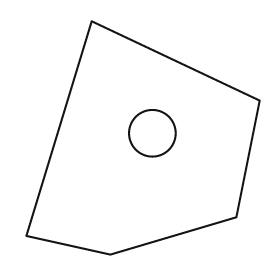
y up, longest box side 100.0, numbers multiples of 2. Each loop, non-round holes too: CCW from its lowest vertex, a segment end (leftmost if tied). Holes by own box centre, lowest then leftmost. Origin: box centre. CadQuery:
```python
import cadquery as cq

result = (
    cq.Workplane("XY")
    .moveTo(-14.0, -50.0)
    .lineTo(40.0, -34.0)
    .lineTo(50.0, 16.0)
    .lineTo(-22.0, 50.0)
    .lineTo(-50.0, -42.0)
    .close()
    .moveTo(4.0, 2.0)
    .circle(10.0)
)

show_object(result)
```